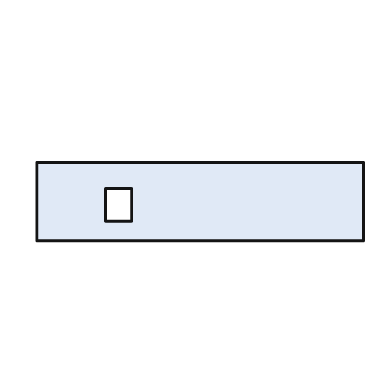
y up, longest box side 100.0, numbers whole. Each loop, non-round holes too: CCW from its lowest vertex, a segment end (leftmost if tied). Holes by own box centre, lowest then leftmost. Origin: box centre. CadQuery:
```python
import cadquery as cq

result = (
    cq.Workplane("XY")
    .moveTo(-50.0, -12.0)
    .lineTo(50.0, -12.0)
    .lineTo(50.0, 12.0)
    .lineTo(-50.0, 12.0)
    .close()
    .moveTo(-29.0, -6.0)
    .lineTo(-21.0, -6.0)
    .lineTo(-21.0, 4.0)
    .lineTo(-29.0, 4.0)
    .close()
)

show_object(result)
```